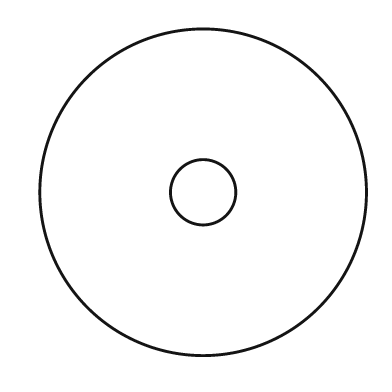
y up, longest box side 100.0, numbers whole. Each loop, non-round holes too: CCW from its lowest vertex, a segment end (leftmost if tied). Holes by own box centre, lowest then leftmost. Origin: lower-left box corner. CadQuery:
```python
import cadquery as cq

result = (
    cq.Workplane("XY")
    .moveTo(50.0, 50.0)
    .circle(50.0)
    .moveTo(50.0, 50.0)
    .circle(10.0)
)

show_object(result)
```